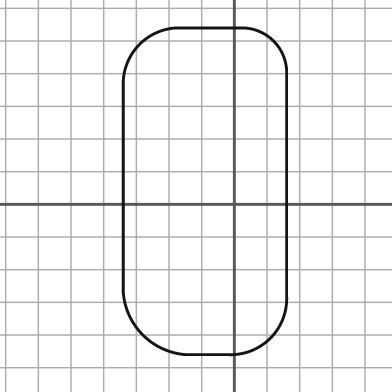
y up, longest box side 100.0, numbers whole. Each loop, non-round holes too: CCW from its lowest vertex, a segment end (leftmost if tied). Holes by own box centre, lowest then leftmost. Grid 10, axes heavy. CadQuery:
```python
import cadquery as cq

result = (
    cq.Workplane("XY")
    .moveTo(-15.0, -46.0)
    .lineTo(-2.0, -46.0)
    .threePointArc((11.0, -41.0), (16.0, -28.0))
    .lineTo(16.0, 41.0)
    .threePointArc((12.0, 50.0), (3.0, 54.0))
    .lineTo(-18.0, 54.0)
    .threePointArc((-29.0, 49.0), (-34.0, 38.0))
    .lineTo(-34.0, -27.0)
    .threePointArc((-28.0, -40.0), (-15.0, -46.0))
    .close()
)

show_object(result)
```